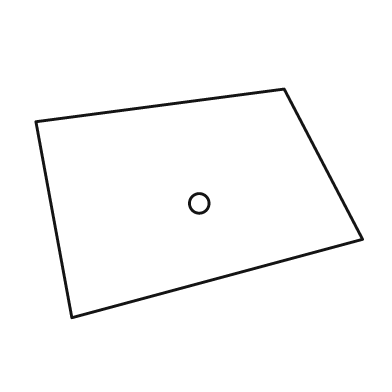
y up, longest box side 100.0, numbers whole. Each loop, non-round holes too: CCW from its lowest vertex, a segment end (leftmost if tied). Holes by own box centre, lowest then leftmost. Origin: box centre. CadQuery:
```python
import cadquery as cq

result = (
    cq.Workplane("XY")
    .moveTo(-39.0, -35.0)
    .lineTo(50.0, -11.0)
    .lineTo(26.0, 35.0)
    .lineTo(-50.0, 25.0)
    .close()
    .moveTo(0.0, 0.0)
    .circle(3.0)
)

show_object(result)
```